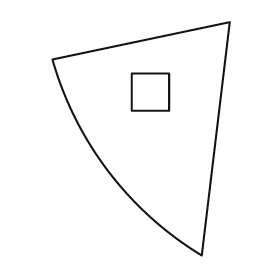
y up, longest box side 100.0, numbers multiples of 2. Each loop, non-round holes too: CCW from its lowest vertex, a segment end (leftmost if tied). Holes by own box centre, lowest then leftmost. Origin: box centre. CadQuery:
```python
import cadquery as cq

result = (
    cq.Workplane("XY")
    .moveTo(26.0, -50.0)
    .lineTo(38.0, 50.0)
    .lineTo(-38.0, 34.0)
    .threePointArc((-14.0, -14.0), (26.0, -50.0))
    .close()
    .moveTo(-4.0, 12.0)
    .lineTo(12.0, 12.0)
    .lineTo(12.0, 28.0)
    .lineTo(-4.0, 28.0)
    .close()
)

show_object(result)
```